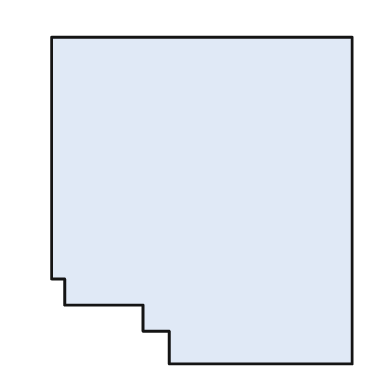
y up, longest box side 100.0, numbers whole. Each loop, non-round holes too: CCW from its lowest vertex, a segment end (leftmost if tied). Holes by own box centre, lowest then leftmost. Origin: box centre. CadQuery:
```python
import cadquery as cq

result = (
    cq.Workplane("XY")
    .moveTo(-10.0, -50.0)
    .lineTo(46.0, -50.0)
    .lineTo(46.0, 50.0)
    .lineTo(-46.0, 50.0)
    .lineTo(-46.0, -24.0)
    .lineTo(-42.0, -24.0)
    .lineTo(-42.0, -32.0)
    .lineTo(-18.0, -32.0)
    .lineTo(-18.0, -40.0)
    .lineTo(-10.0, -40.0)
    .close()
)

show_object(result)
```